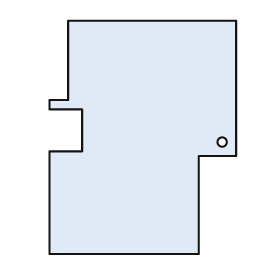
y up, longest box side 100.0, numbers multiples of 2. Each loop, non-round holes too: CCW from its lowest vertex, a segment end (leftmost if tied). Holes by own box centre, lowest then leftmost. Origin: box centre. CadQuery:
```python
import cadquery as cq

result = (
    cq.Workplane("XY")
    .moveTo(-40.0, -50.0)
    .lineTo(24.0, -50.0)
    .lineTo(24.0, -8.0)
    .lineTo(40.0, -8.0)
    .lineTo(40.0, 50.0)
    .lineTo(-32.0, 50.0)
    .lineTo(-32.0, 16.0)
    .lineTo(-40.0, 16.0)
    .lineTo(-40.0, 12.0)
    .lineTo(-26.0, 12.0)
    .lineTo(-26.0, -6.0)
    .lineTo(-40.0, -6.0)
    .close()
    .moveTo(34.0, -2.0)
    .circle(2.0)
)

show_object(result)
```